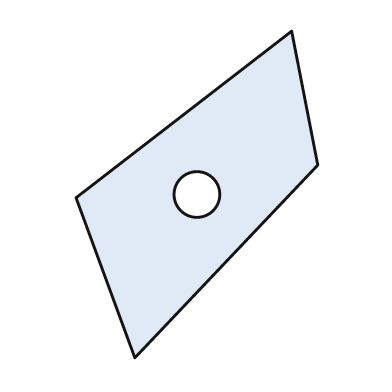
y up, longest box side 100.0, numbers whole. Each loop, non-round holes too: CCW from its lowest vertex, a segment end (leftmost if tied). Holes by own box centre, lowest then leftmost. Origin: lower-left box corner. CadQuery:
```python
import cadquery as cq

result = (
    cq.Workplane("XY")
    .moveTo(18.0, 0.0)
    .lineTo(74.0, 59.0)
    .lineTo(66.0, 100.0)
    .lineTo(0.0, 49.0)
    .close()
    .moveTo(37.0, 50.0)
    .circle(7.0)
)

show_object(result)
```